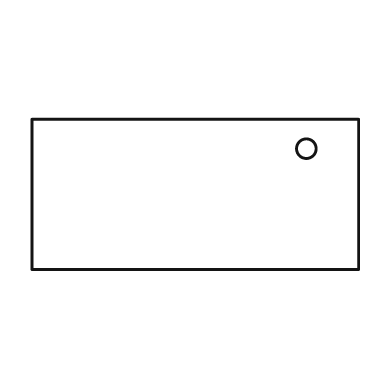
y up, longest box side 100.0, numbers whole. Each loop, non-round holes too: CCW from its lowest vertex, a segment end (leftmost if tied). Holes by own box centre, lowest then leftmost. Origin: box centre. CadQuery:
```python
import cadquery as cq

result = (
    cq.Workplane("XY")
    .moveTo(-50.0, -23.0)
    .lineTo(50.0, -23.0)
    .lineTo(50.0, 23.0)
    .lineTo(-50.0, 23.0)
    .close()
    .moveTo(34.0, 14.0)
    .circle(3.0)
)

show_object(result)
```